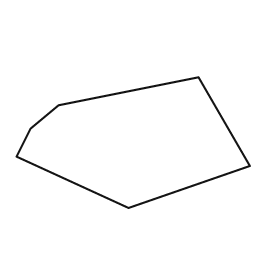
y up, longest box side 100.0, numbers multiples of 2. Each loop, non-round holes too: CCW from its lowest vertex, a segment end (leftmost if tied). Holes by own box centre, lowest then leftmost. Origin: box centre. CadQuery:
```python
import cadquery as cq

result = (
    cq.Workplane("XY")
    .moveTo(-2.0, -28.0)
    .lineTo(50.0, -10.0)
    .lineTo(28.0, 28.0)
    .lineTo(-32.0, 16.0)
    .lineTo(-44.0, 6.0)
    .lineTo(-50.0, -6.0)
    .close()
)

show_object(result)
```